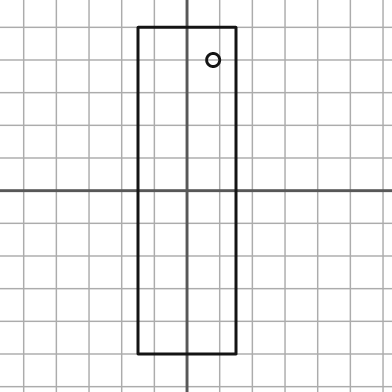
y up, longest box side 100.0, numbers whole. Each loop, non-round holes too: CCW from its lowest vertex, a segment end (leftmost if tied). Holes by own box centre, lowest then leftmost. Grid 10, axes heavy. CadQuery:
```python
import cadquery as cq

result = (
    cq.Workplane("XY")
    .moveTo(-15.0, -50.0)
    .lineTo(15.0, -50.0)
    .lineTo(15.0, 50.0)
    .lineTo(-15.0, 50.0)
    .close()
    .moveTo(8.0, 40.0)
    .circle(2.0)
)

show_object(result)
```